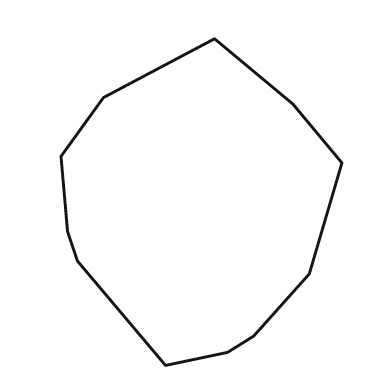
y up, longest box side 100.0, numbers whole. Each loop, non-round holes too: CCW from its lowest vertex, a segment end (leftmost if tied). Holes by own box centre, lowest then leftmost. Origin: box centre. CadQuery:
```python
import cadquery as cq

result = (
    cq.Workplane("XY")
    .moveTo(-11.0, -50.0)
    .lineTo(8.0, -46.0)
    .lineTo(16.0, -41.0)
    .lineTo(33.0, -22.0)
    .lineTo(43.0, 12.0)
    .lineTo(28.0, 30.0)
    .lineTo(4.0, 50.0)
    .lineTo(-30.0, 32.0)
    .lineTo(-43.0, 14.0)
    .lineTo(-41.0, -9.0)
    .lineTo(-38.0, -18.0)
    .close()
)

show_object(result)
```